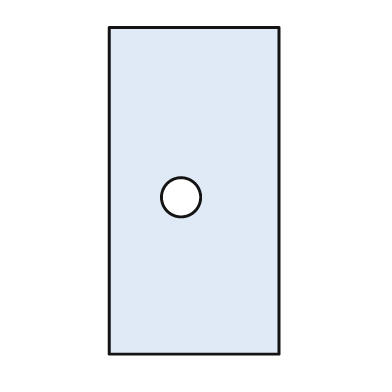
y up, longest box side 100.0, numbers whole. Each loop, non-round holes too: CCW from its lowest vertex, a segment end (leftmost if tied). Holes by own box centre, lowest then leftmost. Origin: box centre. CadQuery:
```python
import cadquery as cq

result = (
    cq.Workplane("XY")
    .moveTo(-26.0, -50.0)
    .lineTo(26.0, -50.0)
    .lineTo(26.0, 50.0)
    .lineTo(-26.0, 50.0)
    .close()
    .moveTo(-4.0, -2.0)
    .circle(6.0)
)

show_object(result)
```